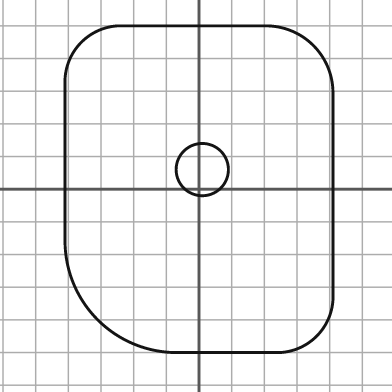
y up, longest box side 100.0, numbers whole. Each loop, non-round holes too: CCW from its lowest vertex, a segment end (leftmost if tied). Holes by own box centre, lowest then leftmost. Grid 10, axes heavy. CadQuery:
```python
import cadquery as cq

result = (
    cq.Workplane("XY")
    .moveTo(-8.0, -50.0)
    .lineTo(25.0, -50.0)
    .threePointArc((36.0, -45.0), (41.0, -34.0))
    .lineTo(41.0, 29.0)
    .threePointArc((35.0, 44.0), (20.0, 50.0))
    .lineTo(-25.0, 50.0)
    .threePointArc((-36.0, 45.0), (-41.0, 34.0))
    .lineTo(-41.0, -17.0)
    .threePointArc((-31.0, -40.0), (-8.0, -50.0))
    .close()
    .moveTo(1.0, 6.0)
    .circle(8.0)
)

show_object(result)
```